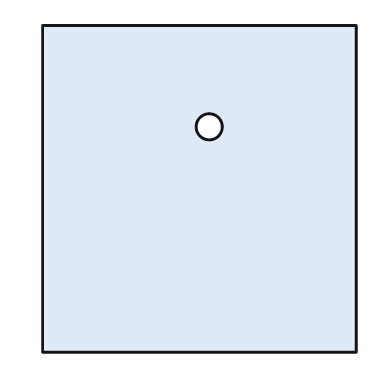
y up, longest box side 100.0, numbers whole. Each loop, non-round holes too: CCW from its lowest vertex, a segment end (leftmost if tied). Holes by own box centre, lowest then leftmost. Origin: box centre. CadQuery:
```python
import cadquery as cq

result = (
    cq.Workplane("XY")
    .moveTo(-48.0, -50.0)
    .lineTo(48.0, -50.0)
    .lineTo(48.0, 50.0)
    .lineTo(-48.0, 50.0)
    .close()
    .moveTo(3.0, 19.0)
    .circle(4.0)
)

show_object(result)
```